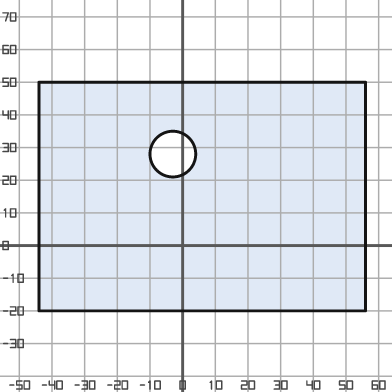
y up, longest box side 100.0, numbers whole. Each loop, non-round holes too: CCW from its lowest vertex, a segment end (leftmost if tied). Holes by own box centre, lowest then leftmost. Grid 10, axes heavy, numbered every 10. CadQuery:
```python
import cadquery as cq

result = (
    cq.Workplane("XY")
    .moveTo(-44.0, -20.0)
    .lineTo(56.0, -20.0)
    .lineTo(56.0, 50.0)
    .lineTo(-44.0, 50.0)
    .close()
    .moveTo(-3.0, 28.0)
    .circle(7.0)
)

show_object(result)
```